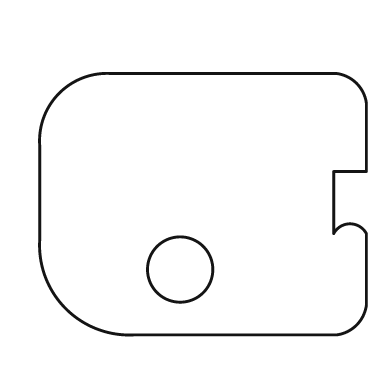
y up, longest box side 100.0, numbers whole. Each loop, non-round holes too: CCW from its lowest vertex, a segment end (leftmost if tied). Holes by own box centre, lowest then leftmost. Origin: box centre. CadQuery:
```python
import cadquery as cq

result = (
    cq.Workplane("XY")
    .moveTo(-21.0, -40.0)
    .lineTo(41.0, -40.0)
    .threePointArc((47.0, -37.0), (50.0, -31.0))
    .lineTo(50.0, -9.0)
    .threePointArc((45.0, -6.0), (40.0, -9.0))
    .lineTo(40.0, 10.0)
    .lineTo(50.0, 10.0)
    .lineTo(50.0, 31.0)
    .threePointArc((47.0, 37.0), (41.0, 40.0))
    .lineTo(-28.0, 40.0)
    .threePointArc((-44.0, 34.0), (-50.0, 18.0))
    .lineTo(-50.0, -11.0)
    .threePointArc((-42.0, -32.0), (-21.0, -40.0))
    .close()
    .moveTo(-7.0, -20.0)
    .circle(10.0)
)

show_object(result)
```